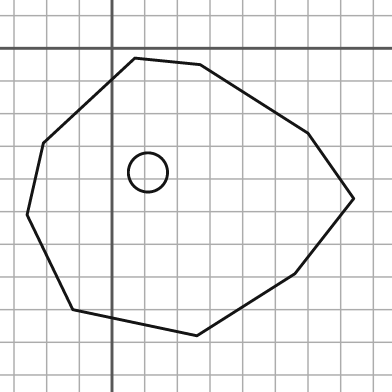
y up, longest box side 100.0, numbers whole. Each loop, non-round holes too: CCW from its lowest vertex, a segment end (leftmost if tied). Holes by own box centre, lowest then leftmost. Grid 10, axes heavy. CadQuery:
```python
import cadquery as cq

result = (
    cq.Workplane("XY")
    .moveTo(26.0, -88.0)
    .lineTo(56.0, -69.0)
    .lineTo(74.0, -46.0)
    .lineTo(60.0, -26.0)
    .lineTo(27.0, -5.0)
    .lineTo(7.0, -3.0)
    .lineTo(-21.0, -29.0)
    .lineTo(-26.0, -51.0)
    .lineTo(-12.0, -80.0)
    .close()
    .moveTo(11.0, -38.0)
    .circle(6.0)
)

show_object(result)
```